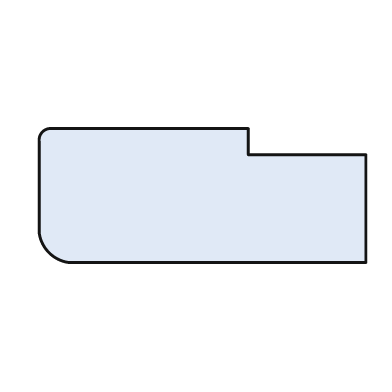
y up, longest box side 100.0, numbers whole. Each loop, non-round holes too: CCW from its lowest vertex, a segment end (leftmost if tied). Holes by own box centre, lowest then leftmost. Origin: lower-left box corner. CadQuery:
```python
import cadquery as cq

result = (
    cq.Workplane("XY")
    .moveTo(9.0, 0.0)
    .lineTo(100.0, 0.0)
    .lineTo(100.0, 33.0)
    .lineTo(64.0, 33.0)
    .lineTo(64.0, 41.0)
    .lineTo(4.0, 41.0)
    .threePointArc((1.0, 40.0), (0.0, 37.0))
    .lineTo(0.0, 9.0)
    .threePointArc((3.0, 3.0), (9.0, 0.0))
    .close()
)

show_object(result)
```